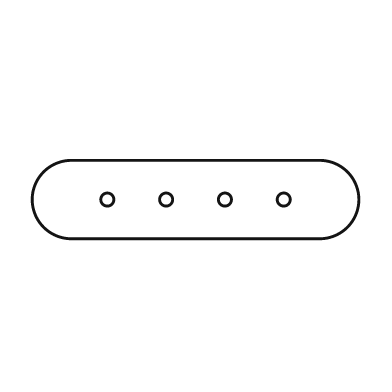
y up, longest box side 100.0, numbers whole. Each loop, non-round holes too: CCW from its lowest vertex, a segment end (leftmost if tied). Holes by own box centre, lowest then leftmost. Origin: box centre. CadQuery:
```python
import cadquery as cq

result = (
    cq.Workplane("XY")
    .moveTo(-38.0, -12.0)
    .lineTo(38.0, -12.0)
    .threePointArc((50.0, 0.0), (38.0, 12.0))
    .lineTo(-38.0, 12.0)
    .threePointArc((-50.0, 0.0), (-38.0, -12.0))
    .close()
    .moveTo(-27.0, 0.0)
    .circle(2.0)
    .moveTo(-9.0, 0.0)
    .circle(2.0)
    .moveTo(9.0, 0.0)
    .circle(2.0)
    .moveTo(27.0, 0.0)
    .circle(2.0)
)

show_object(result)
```